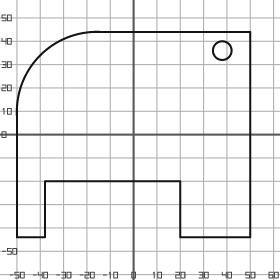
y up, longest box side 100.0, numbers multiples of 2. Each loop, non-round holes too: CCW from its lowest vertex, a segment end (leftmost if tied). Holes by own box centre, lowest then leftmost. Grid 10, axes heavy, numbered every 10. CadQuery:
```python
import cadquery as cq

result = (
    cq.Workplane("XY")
    .moveTo(-50.0, -44.0)
    .lineTo(-38.0, -44.0)
    .lineTo(-38.0, -20.0)
    .lineTo(20.0, -20.0)
    .lineTo(20.0, -44.0)
    .lineTo(50.0, -44.0)
    .lineTo(50.0, 44.0)
    .lineTo(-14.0, 44.0)
    .threePointArc((-40.0, 34.0), (-50.0, 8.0))
    .close()
    .moveTo(38.0, 36.0)
    .circle(4.0)
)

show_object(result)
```